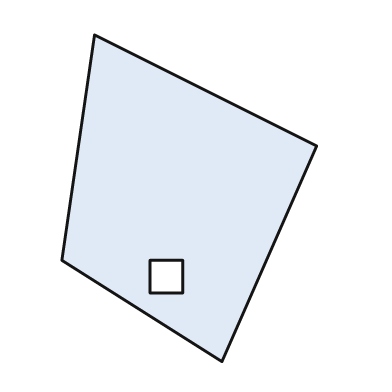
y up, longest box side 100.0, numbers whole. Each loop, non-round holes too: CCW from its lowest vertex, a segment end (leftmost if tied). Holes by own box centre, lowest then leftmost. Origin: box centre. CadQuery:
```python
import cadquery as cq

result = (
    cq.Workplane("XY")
    .moveTo(10.0, -50.0)
    .lineTo(39.0, 16.0)
    .lineTo(-29.0, 50.0)
    .lineTo(-39.0, -19.0)
    .close()
    .moveTo(-12.0, -29.0)
    .lineTo(-2.0, -29.0)
    .lineTo(-2.0, -19.0)
    .lineTo(-12.0, -19.0)
    .close()
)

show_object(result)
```